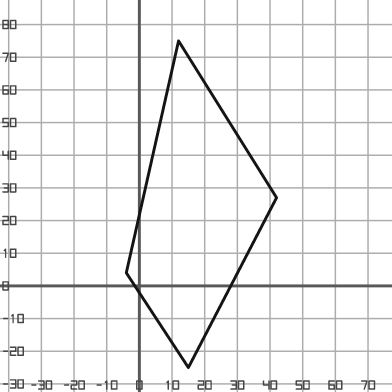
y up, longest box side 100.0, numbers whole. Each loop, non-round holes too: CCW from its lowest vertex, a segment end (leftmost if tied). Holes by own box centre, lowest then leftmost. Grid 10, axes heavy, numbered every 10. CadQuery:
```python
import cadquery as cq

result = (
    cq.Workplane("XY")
    .moveTo(15.0, -25.0)
    .lineTo(42.0, 27.0)
    .lineTo(12.0, 75.0)
    .lineTo(-4.0, 4.0)
    .close()
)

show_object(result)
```